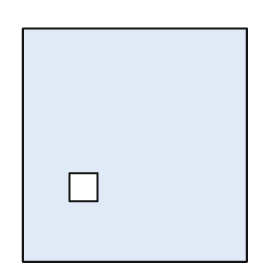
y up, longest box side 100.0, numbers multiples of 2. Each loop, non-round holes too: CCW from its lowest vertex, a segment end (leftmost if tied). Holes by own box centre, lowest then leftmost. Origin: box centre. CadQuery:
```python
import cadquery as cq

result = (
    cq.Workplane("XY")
    .moveTo(-48.0, -50.0)
    .lineTo(48.0, -50.0)
    .lineTo(48.0, 50.0)
    .lineTo(-48.0, 50.0)
    .close()
    .moveTo(-28.0, -24.0)
    .lineTo(-16.0, -24.0)
    .lineTo(-16.0, -12.0)
    .lineTo(-28.0, -12.0)
    .close()
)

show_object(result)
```